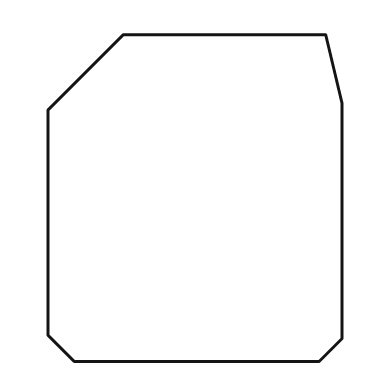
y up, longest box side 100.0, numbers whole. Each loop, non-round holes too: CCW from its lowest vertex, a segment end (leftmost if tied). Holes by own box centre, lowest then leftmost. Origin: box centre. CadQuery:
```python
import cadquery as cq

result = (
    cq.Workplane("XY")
    .moveTo(-37.0, -50.0)
    .lineTo(38.0, -50.0)
    .lineTo(45.0, -43.0)
    .lineTo(45.0, 29.0)
    .lineTo(40.0, 50.0)
    .lineTo(-22.0, 50.0)
    .lineTo(-45.0, 27.0)
    .lineTo(-45.0, -42.0)
    .close()
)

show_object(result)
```